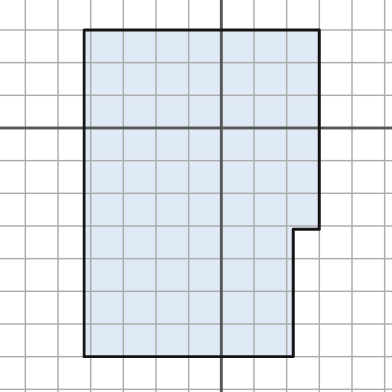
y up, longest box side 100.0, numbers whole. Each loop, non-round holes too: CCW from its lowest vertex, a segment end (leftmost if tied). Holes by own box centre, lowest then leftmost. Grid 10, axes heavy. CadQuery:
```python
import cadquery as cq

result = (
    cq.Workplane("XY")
    .moveTo(-42.0, -70.0)
    .lineTo(22.0, -70.0)
    .lineTo(22.0, -31.0)
    .lineTo(30.0, -31.0)
    .lineTo(30.0, 30.0)
    .lineTo(-42.0, 30.0)
    .close()
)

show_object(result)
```